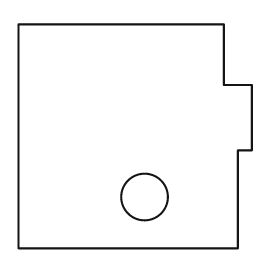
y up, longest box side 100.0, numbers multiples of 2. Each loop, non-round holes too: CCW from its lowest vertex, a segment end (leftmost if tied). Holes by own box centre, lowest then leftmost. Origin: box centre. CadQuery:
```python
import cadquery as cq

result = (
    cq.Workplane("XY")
    .moveTo(-50.0, -48.0)
    .lineTo(44.0, -48.0)
    .lineTo(44.0, -6.0)
    .lineTo(50.0, -6.0)
    .lineTo(50.0, 22.0)
    .lineTo(38.0, 22.0)
    .lineTo(38.0, 48.0)
    .lineTo(-50.0, 48.0)
    .close()
    .moveTo(4.0, -26.0)
    .circle(10.0)
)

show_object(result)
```